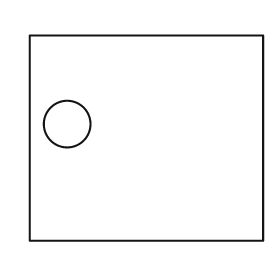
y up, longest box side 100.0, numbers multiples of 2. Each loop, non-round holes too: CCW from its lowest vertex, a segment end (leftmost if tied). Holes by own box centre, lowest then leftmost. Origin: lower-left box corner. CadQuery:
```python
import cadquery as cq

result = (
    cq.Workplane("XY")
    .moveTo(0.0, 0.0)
    .lineTo(100.0, 0.0)
    .lineTo(100.0, 88.0)
    .lineTo(0.0, 88.0)
    .close()
    .moveTo(16.0, 50.0)
    .circle(10.0)
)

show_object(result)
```